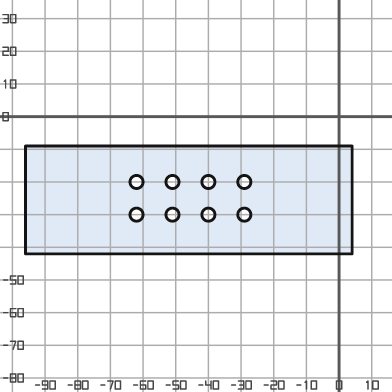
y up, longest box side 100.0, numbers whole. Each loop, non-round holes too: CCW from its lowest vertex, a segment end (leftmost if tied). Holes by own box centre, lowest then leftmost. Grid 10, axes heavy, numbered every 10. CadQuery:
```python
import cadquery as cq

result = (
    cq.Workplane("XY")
    .moveTo(-96.0, -42.0)
    .lineTo(4.0, -42.0)
    .lineTo(4.0, -9.0)
    .lineTo(-96.0, -9.0)
    .close()
    .moveTo(-62.0, -30.0)
    .circle(2.0)
    .moveTo(-51.0, -30.0)
    .circle(2.0)
    .moveTo(-40.0, -30.0)
    .circle(2.0)
    .moveTo(-29.0, -30.0)
    .circle(2.0)
    .moveTo(-62.0, -20.0)
    .circle(2.0)
    .moveTo(-51.0, -20.0)
    .circle(2.0)
    .moveTo(-40.0, -20.0)
    .circle(2.0)
    .moveTo(-29.0, -20.0)
    .circle(2.0)
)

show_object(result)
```